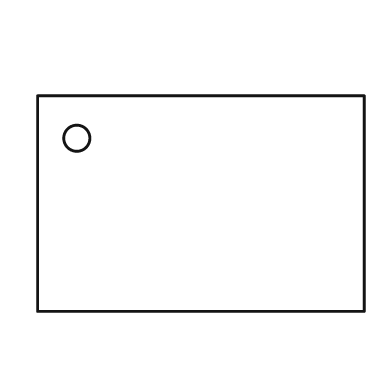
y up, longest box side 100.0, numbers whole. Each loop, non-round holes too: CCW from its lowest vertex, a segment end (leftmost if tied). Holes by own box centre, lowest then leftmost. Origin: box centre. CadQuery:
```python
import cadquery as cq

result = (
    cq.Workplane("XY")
    .moveTo(-50.0, -33.0)
    .lineTo(50.0, -33.0)
    .lineTo(50.0, 33.0)
    .lineTo(-50.0, 33.0)
    .close()
    .moveTo(-38.0, 20.0)
    .circle(4.0)
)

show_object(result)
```